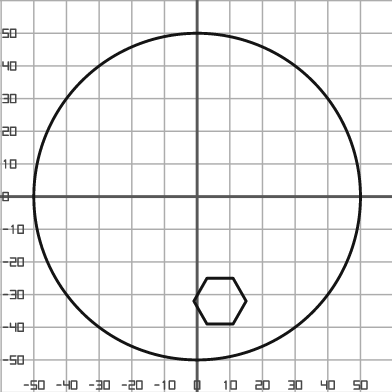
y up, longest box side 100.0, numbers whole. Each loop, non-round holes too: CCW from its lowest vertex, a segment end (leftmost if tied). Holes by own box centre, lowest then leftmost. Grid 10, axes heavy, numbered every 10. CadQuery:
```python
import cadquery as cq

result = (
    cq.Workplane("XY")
    .moveTo(0.0, 0.0)
    .circle(50.0)
    .moveTo(3.0, -39.0)
    .lineTo(11.0, -39.0)
    .lineTo(15.0, -32.0)
    .lineTo(11.0, -25.0)
    .lineTo(3.0, -25.0)
    .lineTo(-1.0, -32.0)
    .close()
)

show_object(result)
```